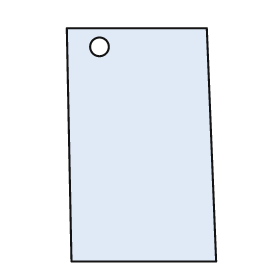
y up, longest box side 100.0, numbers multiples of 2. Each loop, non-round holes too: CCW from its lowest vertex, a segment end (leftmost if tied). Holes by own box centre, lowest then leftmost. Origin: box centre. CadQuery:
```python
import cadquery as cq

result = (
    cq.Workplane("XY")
    .moveTo(-30.0, -50.0)
    .lineTo(32.0, -50.0)
    .lineTo(28.0, 50.0)
    .lineTo(-32.0, 50.0)
    .close()
    .moveTo(-18.0, 42.0)
    .circle(4.0)
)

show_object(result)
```